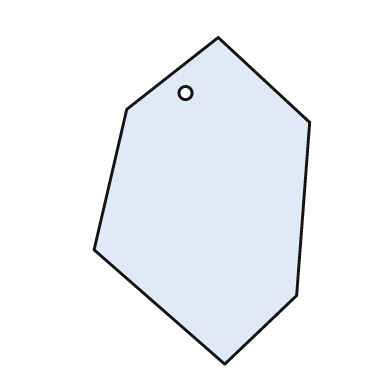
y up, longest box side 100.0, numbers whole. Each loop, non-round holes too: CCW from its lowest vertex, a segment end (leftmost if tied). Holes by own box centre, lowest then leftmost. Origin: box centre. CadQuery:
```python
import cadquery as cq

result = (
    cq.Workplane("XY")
    .moveTo(7.0, -50.0)
    .lineTo(29.0, -29.0)
    .lineTo(33.0, 24.0)
    .lineTo(5.0, 50.0)
    .lineTo(-23.0, 28.0)
    .lineTo(-33.0, -15.0)
    .close()
    .moveTo(-5.0, 33.0)
    .circle(2.0)
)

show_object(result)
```